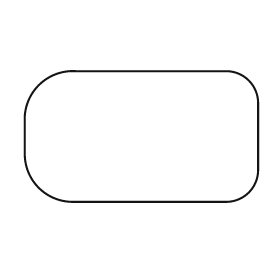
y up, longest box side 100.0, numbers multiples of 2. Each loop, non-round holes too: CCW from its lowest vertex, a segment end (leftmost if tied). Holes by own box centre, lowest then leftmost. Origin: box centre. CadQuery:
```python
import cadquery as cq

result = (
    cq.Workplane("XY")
    .moveTo(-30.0, -28.0)
    .lineTo(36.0, -28.0)
    .threePointArc((46.0, -24.0), (50.0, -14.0))
    .lineTo(50.0, 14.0)
    .threePointArc((46.0, 24.0), (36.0, 28.0))
    .lineTo(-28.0, 28.0)
    .threePointArc((-44.0, 22.0), (-50.0, 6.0))
    .lineTo(-50.0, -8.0)
    .threePointArc((-44.0, -22.0), (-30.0, -28.0))
    .close()
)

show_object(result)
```